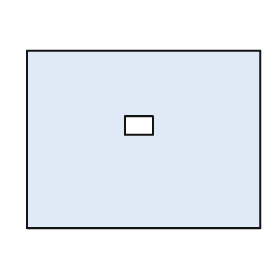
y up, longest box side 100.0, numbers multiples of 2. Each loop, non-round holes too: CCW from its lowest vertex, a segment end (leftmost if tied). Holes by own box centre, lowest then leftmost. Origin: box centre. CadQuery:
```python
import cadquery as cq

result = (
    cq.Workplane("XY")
    .moveTo(-50.0, -38.0)
    .lineTo(50.0, -38.0)
    .lineTo(50.0, 38.0)
    .lineTo(-50.0, 38.0)
    .close()
    .moveTo(-8.0, 2.0)
    .lineTo(4.0, 2.0)
    .lineTo(4.0, 10.0)
    .lineTo(-8.0, 10.0)
    .close()
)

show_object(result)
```